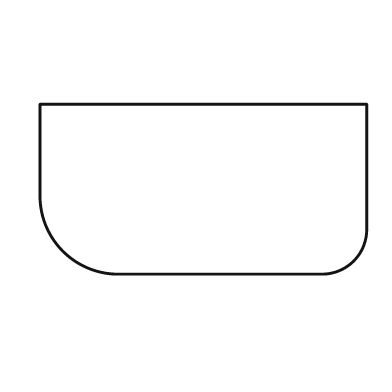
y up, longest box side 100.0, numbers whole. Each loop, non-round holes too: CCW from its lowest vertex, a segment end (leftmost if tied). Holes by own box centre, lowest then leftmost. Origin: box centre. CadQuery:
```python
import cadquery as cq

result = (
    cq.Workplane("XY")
    .moveTo(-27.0, -26.0)
    .lineTo(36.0, -26.0)
    .threePointArc((46.0, -22.0), (50.0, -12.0))
    .lineTo(50.0, 26.0)
    .lineTo(-50.0, 26.0)
    .lineTo(-50.0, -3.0)
    .threePointArc((-43.0, -19.0), (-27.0, -26.0))
    .close()
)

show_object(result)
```